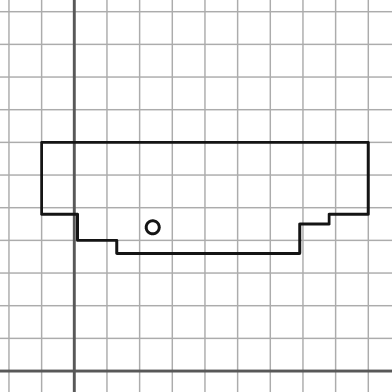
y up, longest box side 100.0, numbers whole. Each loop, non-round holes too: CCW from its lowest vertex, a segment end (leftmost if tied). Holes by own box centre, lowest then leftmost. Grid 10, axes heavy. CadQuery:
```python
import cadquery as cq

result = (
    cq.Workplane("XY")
    .moveTo(13.0, 36.0)
    .lineTo(69.0, 36.0)
    .lineTo(69.0, 45.0)
    .lineTo(78.0, 45.0)
    .lineTo(78.0, 48.0)
    .lineTo(90.0, 48.0)
    .lineTo(90.0, 70.0)
    .lineTo(-10.0, 70.0)
    .lineTo(-10.0, 48.0)
    .lineTo(1.0, 48.0)
    .lineTo(1.0, 40.0)
    .lineTo(13.0, 40.0)
    .close()
    .moveTo(24.0, 44.0)
    .circle(2.0)
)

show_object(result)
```